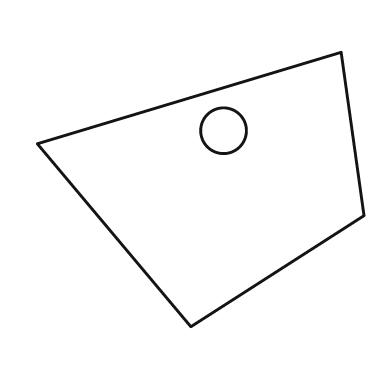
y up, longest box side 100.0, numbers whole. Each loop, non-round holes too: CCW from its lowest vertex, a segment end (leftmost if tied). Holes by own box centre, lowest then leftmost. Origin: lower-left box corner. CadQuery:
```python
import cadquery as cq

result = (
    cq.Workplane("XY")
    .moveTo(47.0, 0.0)
    .lineTo(100.0, 34.0)
    .lineTo(93.0, 84.0)
    .lineTo(0.0, 56.0)
    .close()
    .moveTo(57.0, 60.0)
    .circle(7.0)
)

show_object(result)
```